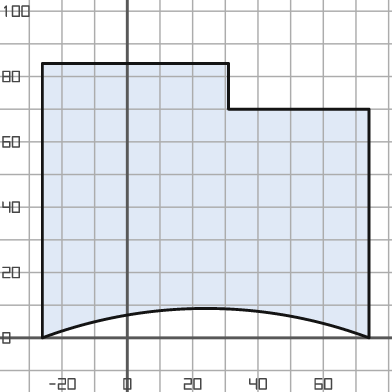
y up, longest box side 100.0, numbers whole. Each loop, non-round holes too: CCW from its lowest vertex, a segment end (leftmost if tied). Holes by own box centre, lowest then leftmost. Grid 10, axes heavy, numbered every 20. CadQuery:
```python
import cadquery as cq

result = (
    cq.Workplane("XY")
    .moveTo(-26.0, 0.0)
    .threePointArc((24.0, 9.0), (74.0, 0.0))
    .lineTo(74.0, 70.0)
    .lineTo(31.0, 70.0)
    .lineTo(31.0, 84.0)
    .lineTo(-26.0, 84.0)
    .close()
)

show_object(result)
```